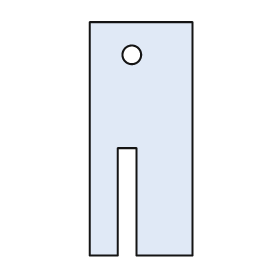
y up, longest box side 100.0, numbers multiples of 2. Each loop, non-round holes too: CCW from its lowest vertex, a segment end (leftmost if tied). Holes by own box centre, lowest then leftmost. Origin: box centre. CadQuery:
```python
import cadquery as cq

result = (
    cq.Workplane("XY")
    .moveTo(-22.0, -50.0)
    .lineTo(-10.0, -50.0)
    .lineTo(-10.0, -4.0)
    .lineTo(-2.0, -4.0)
    .lineTo(-2.0, -50.0)
    .lineTo(22.0, -50.0)
    .lineTo(22.0, 50.0)
    .lineTo(-22.0, 50.0)
    .close()
    .moveTo(-4.0, 36.0)
    .circle(4.0)
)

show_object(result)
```